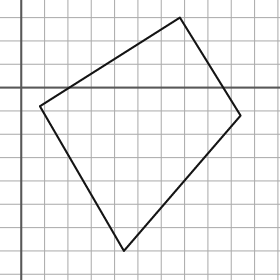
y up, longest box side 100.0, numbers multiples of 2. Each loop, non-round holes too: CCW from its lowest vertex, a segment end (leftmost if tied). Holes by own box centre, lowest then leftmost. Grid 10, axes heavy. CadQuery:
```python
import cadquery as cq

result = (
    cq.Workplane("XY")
    .moveTo(44.0, -70.0)
    .lineTo(94.0, -12.0)
    .lineTo(68.0, 30.0)
    .lineTo(8.0, -8.0)
    .close()
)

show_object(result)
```